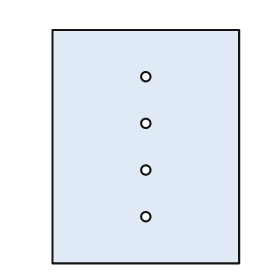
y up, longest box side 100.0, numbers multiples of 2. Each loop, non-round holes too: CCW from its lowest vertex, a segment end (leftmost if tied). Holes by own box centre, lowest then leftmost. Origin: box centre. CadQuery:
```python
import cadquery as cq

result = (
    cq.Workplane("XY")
    .moveTo(-40.0, -50.0)
    .lineTo(40.0, -50.0)
    .lineTo(40.0, 50.0)
    .lineTo(-40.0, 50.0)
    .close()
    .moveTo(0.0, -30.0)
    .circle(2.0)
    .moveTo(0.0, -10.0)
    .circle(2.0)
    .moveTo(0.0, 10.0)
    .circle(2.0)
    .moveTo(0.0, 30.0)
    .circle(2.0)
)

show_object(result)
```